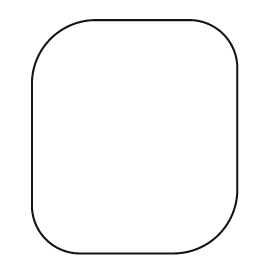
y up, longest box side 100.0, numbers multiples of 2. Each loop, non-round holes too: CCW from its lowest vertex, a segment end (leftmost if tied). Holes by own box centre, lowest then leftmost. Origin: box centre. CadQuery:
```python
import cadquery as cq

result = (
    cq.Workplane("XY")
    .moveTo(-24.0, -50.0)
    .lineTo(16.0, -50.0)
    .threePointArc((36.0, -42.0), (44.0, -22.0))
    .lineTo(44.0, 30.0)
    .threePointArc((38.0, 44.0), (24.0, 50.0))
    .lineTo(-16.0, 50.0)
    .threePointArc((-36.0, 42.0), (-44.0, 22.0))
    .lineTo(-44.0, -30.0)
    .threePointArc((-38.0, -44.0), (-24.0, -50.0))
    .close()
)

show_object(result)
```